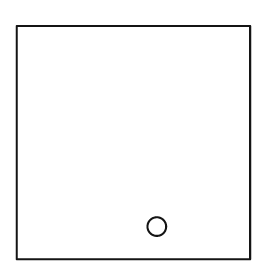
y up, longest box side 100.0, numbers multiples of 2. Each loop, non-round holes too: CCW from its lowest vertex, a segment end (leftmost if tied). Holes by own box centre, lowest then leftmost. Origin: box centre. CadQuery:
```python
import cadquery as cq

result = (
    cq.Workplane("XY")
    .moveTo(-50.0, -50.0)
    .lineTo(50.0, -50.0)
    .lineTo(50.0, 50.0)
    .lineTo(-50.0, 50.0)
    .close()
    .moveTo(10.0, -36.0)
    .circle(4.0)
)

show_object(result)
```